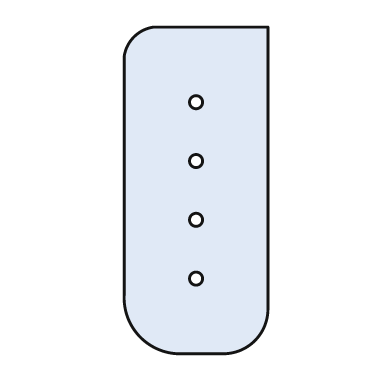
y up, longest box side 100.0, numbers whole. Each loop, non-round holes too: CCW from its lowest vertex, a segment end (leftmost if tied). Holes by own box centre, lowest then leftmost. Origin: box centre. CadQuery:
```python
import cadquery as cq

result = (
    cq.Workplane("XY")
    .moveTo(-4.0, -50.0)
    .lineTo(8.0, -50.0)
    .threePointArc((18.0, -46.0), (22.0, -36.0))
    .lineTo(22.0, 50.0)
    .lineTo(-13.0, 50.0)
    .threePointArc((-19.0, 47.0), (-22.0, 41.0))
    .lineTo(-22.0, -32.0)
    .threePointArc((-17.0, -45.0), (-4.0, -50.0))
    .close()
    .moveTo(0.0, -27.0)
    .circle(2.0)
    .moveTo(0.0, -9.0)
    .circle(2.0)
    .moveTo(0.0, 9.0)
    .circle(2.0)
    .moveTo(0.0, 27.0)
    .circle(2.0)
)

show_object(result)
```